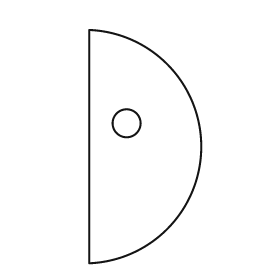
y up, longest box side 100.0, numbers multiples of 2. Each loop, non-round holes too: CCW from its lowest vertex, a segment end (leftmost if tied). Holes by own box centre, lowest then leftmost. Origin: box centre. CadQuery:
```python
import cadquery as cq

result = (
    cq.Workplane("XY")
    .moveTo(-24.0, -50.0)
    .threePointArc((24.0, 0.0), (-24.0, 50.0))
    .close()
    .moveTo(-8.0, 10.0)
    .circle(6.0)
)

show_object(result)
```